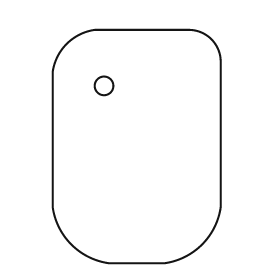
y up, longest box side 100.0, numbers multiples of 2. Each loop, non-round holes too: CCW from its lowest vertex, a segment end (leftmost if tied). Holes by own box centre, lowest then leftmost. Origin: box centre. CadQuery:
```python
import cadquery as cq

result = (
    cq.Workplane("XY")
    .moveTo(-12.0, -50.0)
    .lineTo(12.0, -50.0)
    .threePointArc((28.0, -42.0), (36.0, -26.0))
    .lineTo(36.0, 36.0)
    .threePointArc((32.0, 46.0), (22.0, 50.0))
    .lineTo(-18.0, 50.0)
    .threePointArc((-30.0, 44.0), (-36.0, 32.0))
    .lineTo(-36.0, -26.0)
    .threePointArc((-28.0, -42.0), (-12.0, -50.0))
    .close()
    .moveTo(-14.0, 26.0)
    .circle(4.0)
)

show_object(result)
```